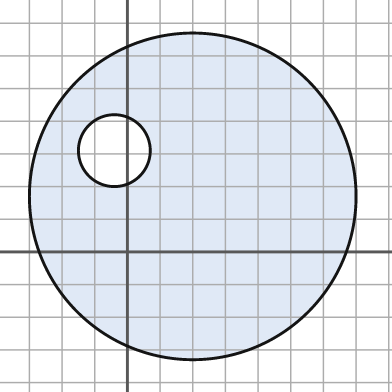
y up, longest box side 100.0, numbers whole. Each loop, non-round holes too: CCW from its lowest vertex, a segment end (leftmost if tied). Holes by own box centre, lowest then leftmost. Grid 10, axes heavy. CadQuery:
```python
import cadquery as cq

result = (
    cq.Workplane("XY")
    .moveTo(20.0, 17.0)
    .circle(50.0)
    .moveTo(-4.0, 31.0)
    .circle(11.0)
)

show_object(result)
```